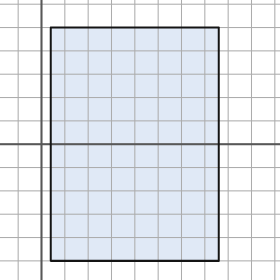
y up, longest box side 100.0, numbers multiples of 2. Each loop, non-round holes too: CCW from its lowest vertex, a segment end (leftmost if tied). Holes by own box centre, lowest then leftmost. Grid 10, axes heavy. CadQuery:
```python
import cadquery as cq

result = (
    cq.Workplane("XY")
    .moveTo(4.0, -50.0)
    .lineTo(76.0, -50.0)
    .lineTo(76.0, 50.0)
    .lineTo(4.0, 50.0)
    .close()
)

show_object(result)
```